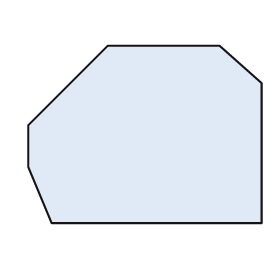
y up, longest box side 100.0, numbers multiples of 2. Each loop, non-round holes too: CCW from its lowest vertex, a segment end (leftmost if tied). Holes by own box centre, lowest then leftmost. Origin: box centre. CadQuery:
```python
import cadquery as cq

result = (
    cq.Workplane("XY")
    .moveTo(-40.0, -38.0)
    .lineTo(50.0, -38.0)
    .lineTo(50.0, 22.0)
    .lineTo(32.0, 38.0)
    .lineTo(-16.0, 38.0)
    .lineTo(-50.0, 4.0)
    .lineTo(-50.0, -14.0)
    .close()
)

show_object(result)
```